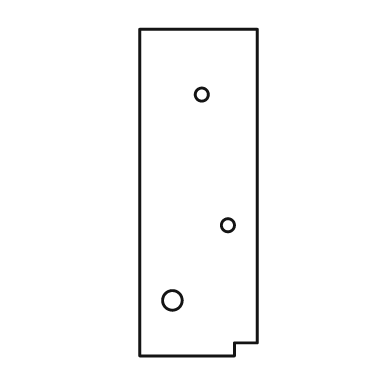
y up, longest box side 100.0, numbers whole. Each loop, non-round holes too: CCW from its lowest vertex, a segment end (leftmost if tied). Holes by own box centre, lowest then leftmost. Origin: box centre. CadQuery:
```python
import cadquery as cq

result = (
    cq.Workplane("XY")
    .moveTo(-18.0, -50.0)
    .lineTo(11.0, -50.0)
    .lineTo(11.0, -46.0)
    .lineTo(18.0, -46.0)
    .lineTo(18.0, 50.0)
    .lineTo(-18.0, 50.0)
    .close()
    .moveTo(-8.0, -33.0)
    .circle(3.0)
    .moveTo(9.0, -10.0)
    .circle(2.0)
    .moveTo(1.0, 30.0)
    .circle(2.0)
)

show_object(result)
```